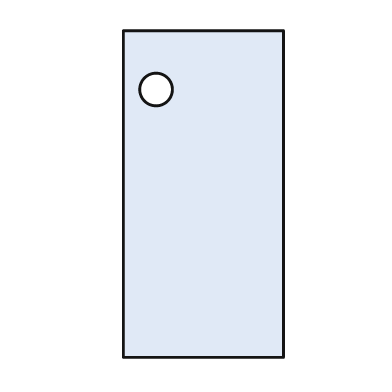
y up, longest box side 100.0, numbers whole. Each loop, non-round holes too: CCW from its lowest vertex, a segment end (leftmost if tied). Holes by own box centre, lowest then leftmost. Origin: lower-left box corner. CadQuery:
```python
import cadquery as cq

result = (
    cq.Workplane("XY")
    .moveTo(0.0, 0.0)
    .lineTo(49.0, 0.0)
    .lineTo(49.0, 100.0)
    .lineTo(0.0, 100.0)
    .close()
    .moveTo(10.0, 82.0)
    .circle(5.0)
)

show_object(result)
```